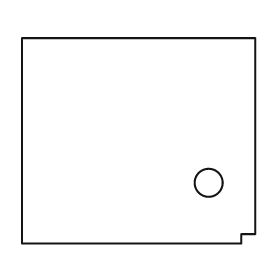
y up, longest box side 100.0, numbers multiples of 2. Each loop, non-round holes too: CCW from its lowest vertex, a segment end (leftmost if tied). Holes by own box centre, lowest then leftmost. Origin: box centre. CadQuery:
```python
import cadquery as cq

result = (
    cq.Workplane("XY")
    .moveTo(-50.0, -44.0)
    .lineTo(44.0, -44.0)
    .lineTo(44.0, -40.0)
    .lineTo(50.0, -40.0)
    .lineTo(50.0, 44.0)
    .lineTo(-50.0, 44.0)
    .close()
    .moveTo(30.0, -18.0)
    .circle(6.0)
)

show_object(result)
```